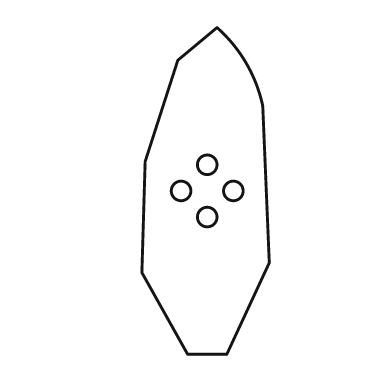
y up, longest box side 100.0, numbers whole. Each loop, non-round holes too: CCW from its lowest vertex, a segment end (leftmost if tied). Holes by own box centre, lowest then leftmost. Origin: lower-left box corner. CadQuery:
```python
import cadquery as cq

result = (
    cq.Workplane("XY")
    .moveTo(14.0, 0.0)
    .lineTo(26.0, 0.0)
    .lineTo(39.0, 28.0)
    .lineTo(37.0, 76.0)
    .threePointArc((32.0, 89.0), (23.0, 100.0))
    .lineTo(11.0, 90.0)
    .lineTo(1.0, 59.0)
    .lineTo(0.0, 25.0)
    .close()
    .moveTo(20.0, 42.0)
    .circle(3.0)
    .moveTo(12.0, 50.0)
    .circle(3.0)
    .moveTo(28.0, 50.0)
    .circle(3.0)
    .moveTo(20.0, 58.0)
    .circle(3.0)
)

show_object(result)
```